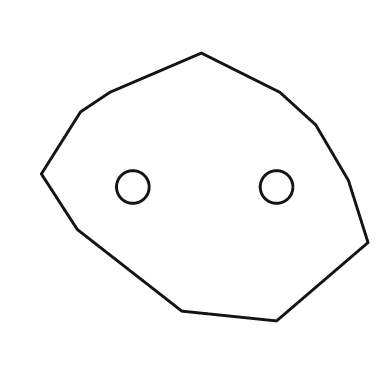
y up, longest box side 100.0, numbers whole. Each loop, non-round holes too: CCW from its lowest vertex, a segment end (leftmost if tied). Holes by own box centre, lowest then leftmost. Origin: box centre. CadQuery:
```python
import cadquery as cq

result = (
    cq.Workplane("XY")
    .moveTo(22.0, -41.0)
    .lineTo(50.0, -17.0)
    .lineTo(44.0, 2.0)
    .lineTo(34.0, 19.0)
    .lineTo(23.0, 29.0)
    .lineTo(-1.0, 41.0)
    .lineTo(-29.0, 29.0)
    .lineTo(-38.0, 23.0)
    .lineTo(-50.0, 4.0)
    .lineTo(-39.0, -13.0)
    .lineTo(-7.0, -38.0)
    .close()
    .moveTo(-22.0, 0.0)
    .circle(5.0)
    .moveTo(22.0, 0.0)
    .circle(5.0)
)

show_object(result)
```